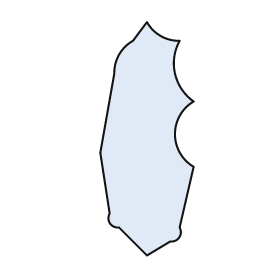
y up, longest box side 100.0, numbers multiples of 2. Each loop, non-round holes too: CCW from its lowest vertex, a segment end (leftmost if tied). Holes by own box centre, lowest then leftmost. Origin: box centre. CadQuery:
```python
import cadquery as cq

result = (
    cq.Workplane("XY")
    .moveTo(0.0, -50.0)
    .lineTo(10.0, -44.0)
    .threePointArc((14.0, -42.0), (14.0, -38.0))
    .lineTo(20.0, -12.0)
    .threePointArc((12.0, 2.0), (20.0, 16.0))
    .threePointArc((12.0, 28.0), (14.0, 42.0))
    .threePointArc((6.0, 44.0), (0.0, 50.0))
    .lineTo(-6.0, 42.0)
    .threePointArc((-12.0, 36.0), (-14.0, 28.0))
    .lineTo(-20.0, -6.0)
    .lineTo(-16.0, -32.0)
    .threePointArc((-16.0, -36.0), (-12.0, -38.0))
    .close()
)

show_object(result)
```